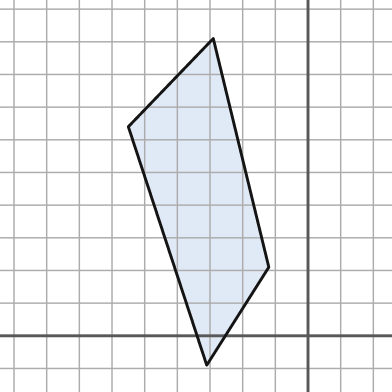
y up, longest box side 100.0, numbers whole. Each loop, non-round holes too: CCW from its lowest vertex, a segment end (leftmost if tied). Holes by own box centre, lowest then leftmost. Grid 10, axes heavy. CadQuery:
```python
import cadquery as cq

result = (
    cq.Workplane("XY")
    .moveTo(-31.0, -9.0)
    .lineTo(-12.0, 21.0)
    .lineTo(-29.0, 91.0)
    .lineTo(-55.0, 64.0)
    .close()
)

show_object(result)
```